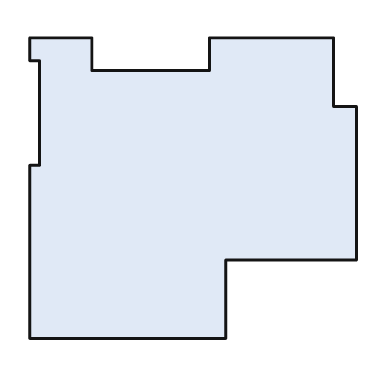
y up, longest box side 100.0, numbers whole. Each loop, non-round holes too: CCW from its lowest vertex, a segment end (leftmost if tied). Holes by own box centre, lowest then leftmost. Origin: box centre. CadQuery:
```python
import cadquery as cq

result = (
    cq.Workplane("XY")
    .moveTo(-50.0, -46.0)
    .lineTo(10.0, -46.0)
    .lineTo(10.0, -22.0)
    .lineTo(50.0, -22.0)
    .lineTo(50.0, 25.0)
    .lineTo(43.0, 25.0)
    .lineTo(43.0, 46.0)
    .lineTo(5.0, 46.0)
    .lineTo(5.0, 36.0)
    .lineTo(-31.0, 36.0)
    .lineTo(-31.0, 46.0)
    .lineTo(-50.0, 46.0)
    .lineTo(-50.0, 39.0)
    .lineTo(-47.0, 39.0)
    .lineTo(-47.0, 7.0)
    .lineTo(-50.0, 7.0)
    .close()
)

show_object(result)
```